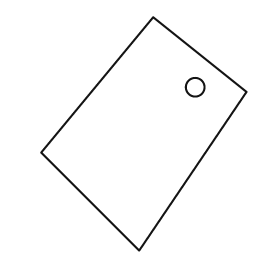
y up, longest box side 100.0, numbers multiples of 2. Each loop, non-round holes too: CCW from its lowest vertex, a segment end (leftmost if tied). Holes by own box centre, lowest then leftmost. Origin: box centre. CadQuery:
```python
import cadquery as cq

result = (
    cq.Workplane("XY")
    .moveTo(-2.0, -50.0)
    .lineTo(44.0, 18.0)
    .lineTo(4.0, 50.0)
    .lineTo(-44.0, -8.0)
    .close()
    .moveTo(22.0, 20.0)
    .circle(4.0)
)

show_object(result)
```